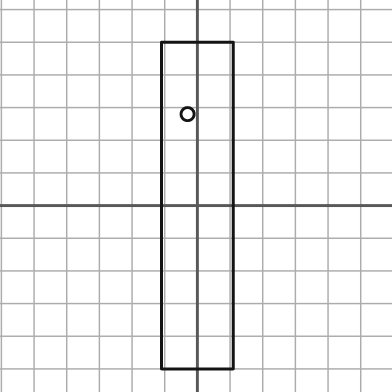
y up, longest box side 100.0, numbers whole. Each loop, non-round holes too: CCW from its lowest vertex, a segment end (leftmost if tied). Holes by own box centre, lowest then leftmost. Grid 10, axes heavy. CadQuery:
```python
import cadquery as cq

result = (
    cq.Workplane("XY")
    .moveTo(-11.0, -50.0)
    .lineTo(11.0, -50.0)
    .lineTo(11.0, 50.0)
    .lineTo(-11.0, 50.0)
    .close()
    .moveTo(-3.0, 28.0)
    .circle(2.0)
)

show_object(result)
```